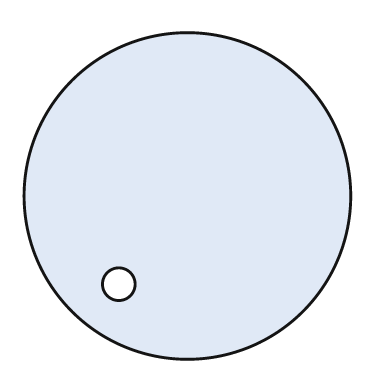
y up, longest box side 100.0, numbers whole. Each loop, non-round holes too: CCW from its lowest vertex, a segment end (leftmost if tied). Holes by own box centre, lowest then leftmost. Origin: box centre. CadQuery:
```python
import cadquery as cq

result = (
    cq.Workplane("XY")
    .moveTo(0.0, 0.0)
    .circle(50.0)
    .moveTo(-21.0, -27.0)
    .circle(5.0)
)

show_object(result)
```